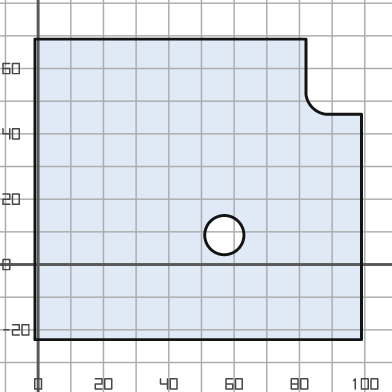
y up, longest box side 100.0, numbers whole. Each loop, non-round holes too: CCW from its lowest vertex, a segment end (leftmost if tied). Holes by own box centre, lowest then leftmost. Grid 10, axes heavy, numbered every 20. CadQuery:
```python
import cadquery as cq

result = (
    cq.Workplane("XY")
    .moveTo(-1.0, -23.0)
    .lineTo(99.0, -23.0)
    .lineTo(99.0, 46.0)
    .lineTo(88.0, 46.0)
    .threePointArc((84.0, 48.0), (82.0, 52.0))
    .lineTo(82.0, 69.0)
    .lineTo(-1.0, 69.0)
    .close()
    .moveTo(57.0, 9.0)
    .circle(6.0)
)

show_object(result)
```